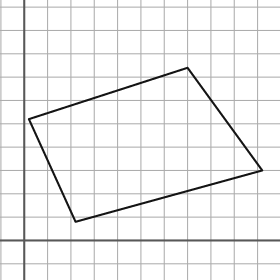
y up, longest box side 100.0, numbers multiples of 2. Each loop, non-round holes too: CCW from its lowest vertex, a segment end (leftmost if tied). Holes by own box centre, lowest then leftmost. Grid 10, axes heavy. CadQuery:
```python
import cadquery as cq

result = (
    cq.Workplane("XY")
    .moveTo(22.0, 8.0)
    .lineTo(102.0, 30.0)
    .lineTo(70.0, 74.0)
    .lineTo(2.0, 52.0)
    .close()
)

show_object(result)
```